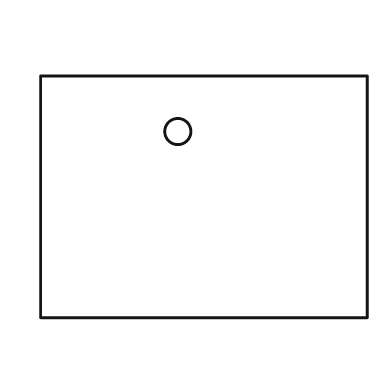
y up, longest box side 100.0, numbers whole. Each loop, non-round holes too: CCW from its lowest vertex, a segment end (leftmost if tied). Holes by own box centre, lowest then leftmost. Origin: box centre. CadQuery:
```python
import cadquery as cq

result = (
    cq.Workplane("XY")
    .moveTo(-50.0, -37.0)
    .lineTo(50.0, -37.0)
    .lineTo(50.0, 37.0)
    .lineTo(-50.0, 37.0)
    .close()
    .moveTo(-8.0, 20.0)
    .circle(4.0)
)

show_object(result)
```